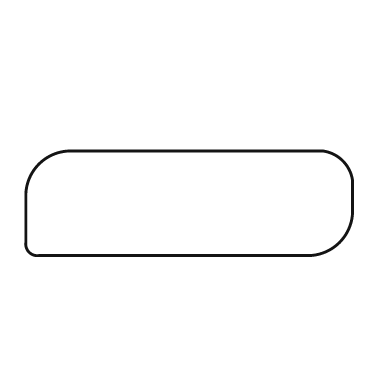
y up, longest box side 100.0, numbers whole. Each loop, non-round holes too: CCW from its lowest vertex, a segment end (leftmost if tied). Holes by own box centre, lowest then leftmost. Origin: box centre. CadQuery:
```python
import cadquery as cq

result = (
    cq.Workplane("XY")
    .moveTo(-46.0, -16.0)
    .lineTo(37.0, -16.0)
    .threePointArc((46.0, -12.0), (50.0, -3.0))
    .lineTo(50.0, 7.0)
    .threePointArc((47.0, 13.0), (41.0, 16.0))
    .lineTo(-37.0, 16.0)
    .threePointArc((-46.0, 12.0), (-50.0, 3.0))
    .lineTo(-50.0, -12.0)
    .threePointArc((-49.0, -15.0), (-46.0, -16.0))
    .close()
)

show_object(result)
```